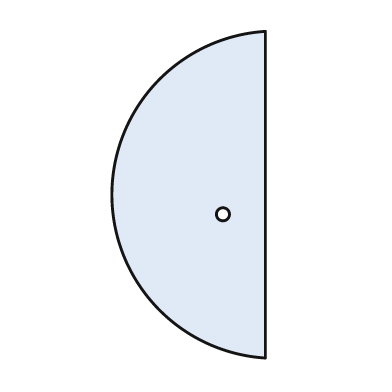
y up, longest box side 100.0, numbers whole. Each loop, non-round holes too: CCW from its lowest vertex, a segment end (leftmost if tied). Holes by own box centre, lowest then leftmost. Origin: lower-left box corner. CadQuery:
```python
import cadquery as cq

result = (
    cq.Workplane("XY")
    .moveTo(47.0, 0.0)
    .lineTo(47.0, 100.0)
    .threePointArc((0.0, 50.0), (47.0, 0.0))
    .close()
    .moveTo(34.0, 44.0)
    .circle(2.0)
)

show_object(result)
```